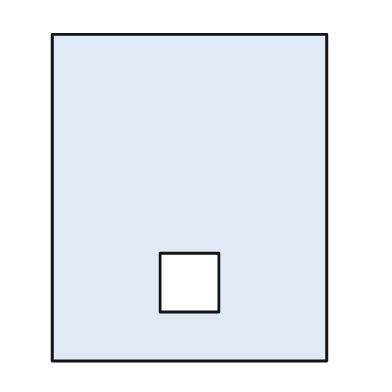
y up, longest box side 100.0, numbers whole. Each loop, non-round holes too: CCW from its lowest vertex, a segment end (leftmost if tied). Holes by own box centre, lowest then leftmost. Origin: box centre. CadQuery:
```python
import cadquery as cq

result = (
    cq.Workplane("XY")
    .moveTo(-42.0, -50.0)
    .lineTo(42.0, -50.0)
    .lineTo(42.0, 50.0)
    .lineTo(-42.0, 50.0)
    .close()
    .moveTo(-9.0, -35.0)
    .lineTo(9.0, -35.0)
    .lineTo(9.0, -17.0)
    .lineTo(-9.0, -17.0)
    .close()
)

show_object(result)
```